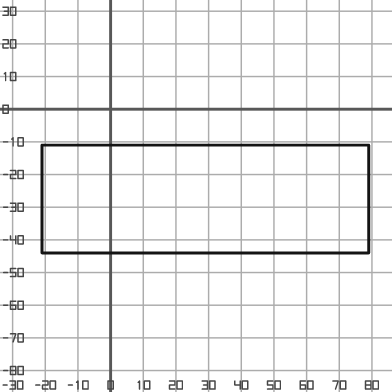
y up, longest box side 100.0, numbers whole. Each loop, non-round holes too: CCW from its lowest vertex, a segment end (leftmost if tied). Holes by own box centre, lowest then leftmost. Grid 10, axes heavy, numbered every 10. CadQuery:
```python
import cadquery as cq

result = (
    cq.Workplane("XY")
    .moveTo(-21.0, -44.0)
    .lineTo(79.0, -44.0)
    .lineTo(79.0, -11.0)
    .lineTo(-21.0, -11.0)
    .close()
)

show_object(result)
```